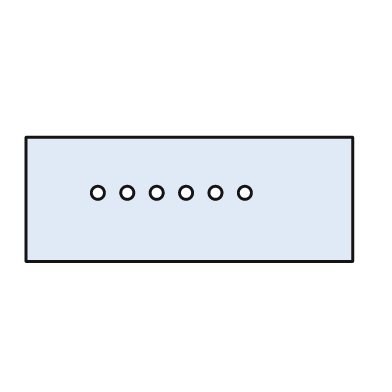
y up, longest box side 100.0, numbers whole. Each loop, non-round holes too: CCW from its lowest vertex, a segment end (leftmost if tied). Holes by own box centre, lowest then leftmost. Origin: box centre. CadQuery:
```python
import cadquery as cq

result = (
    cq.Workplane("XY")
    .moveTo(-50.0, -19.0)
    .lineTo(50.0, -19.0)
    .lineTo(50.0, 19.0)
    .lineTo(-50.0, 19.0)
    .close()
    .moveTo(-28.0, 2.0)
    .circle(2.0)
    .moveTo(-19.0, 2.0)
    .circle(2.0)
    .moveTo(-10.0, 2.0)
    .circle(2.0)
    .moveTo(-1.0, 2.0)
    .circle(2.0)
    .moveTo(8.0, 2.0)
    .circle(2.0)
    .moveTo(17.0, 2.0)
    .circle(2.0)
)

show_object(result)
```